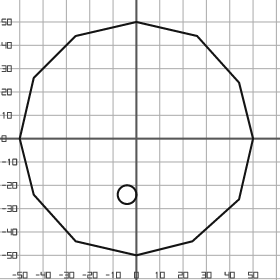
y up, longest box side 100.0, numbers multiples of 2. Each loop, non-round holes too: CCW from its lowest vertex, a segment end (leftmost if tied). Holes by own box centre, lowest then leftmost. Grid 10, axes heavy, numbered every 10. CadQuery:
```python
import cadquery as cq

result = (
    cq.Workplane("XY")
    .moveTo(0.0, -50.0)
    .lineTo(24.0, -44.0)
    .lineTo(44.0, -26.0)
    .lineTo(50.0, 0.0)
    .lineTo(44.0, 24.0)
    .lineTo(26.0, 44.0)
    .lineTo(0.0, 50.0)
    .lineTo(-26.0, 44.0)
    .lineTo(-44.0, 26.0)
    .lineTo(-50.0, 0.0)
    .lineTo(-44.0, -24.0)
    .lineTo(-26.0, -44.0)
    .close()
    .moveTo(-4.0, -24.0)
    .circle(4.0)
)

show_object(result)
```